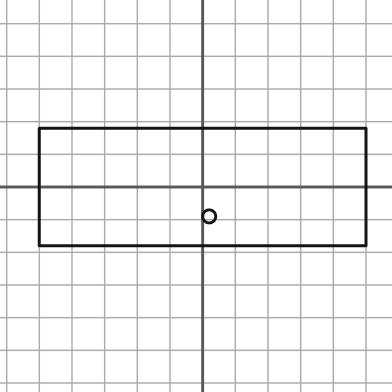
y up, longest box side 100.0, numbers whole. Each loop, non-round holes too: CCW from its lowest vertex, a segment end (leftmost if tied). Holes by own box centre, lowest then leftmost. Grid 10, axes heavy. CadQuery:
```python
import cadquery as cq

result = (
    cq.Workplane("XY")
    .moveTo(-50.0, -18.0)
    .lineTo(50.0, -18.0)
    .lineTo(50.0, 18.0)
    .lineTo(-50.0, 18.0)
    .close()
    .moveTo(2.0, -9.0)
    .circle(2.0)
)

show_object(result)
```